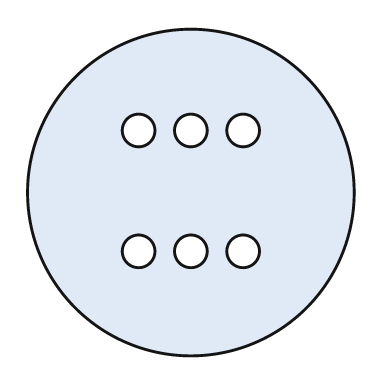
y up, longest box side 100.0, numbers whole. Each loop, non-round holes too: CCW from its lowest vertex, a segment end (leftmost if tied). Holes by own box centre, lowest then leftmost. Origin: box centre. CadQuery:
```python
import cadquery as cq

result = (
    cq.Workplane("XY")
    .moveTo(0.0, 0.0)
    .circle(50.0)
    .moveTo(-16.0, -18.0)
    .circle(5.0)
    .moveTo(0.0, -18.0)
    .circle(5.0)
    .moveTo(16.0, -18.0)
    .circle(5.0)
    .moveTo(-16.0, 19.0)
    .circle(5.0)
    .moveTo(0.0, 19.0)
    .circle(5.0)
    .moveTo(16.0, 19.0)
    .circle(5.0)
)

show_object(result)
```